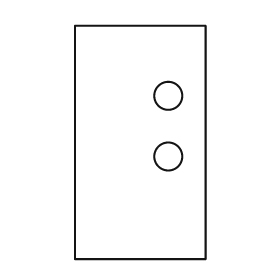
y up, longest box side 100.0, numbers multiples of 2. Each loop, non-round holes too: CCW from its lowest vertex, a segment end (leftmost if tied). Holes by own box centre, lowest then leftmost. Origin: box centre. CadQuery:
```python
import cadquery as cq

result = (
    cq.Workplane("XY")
    .moveTo(-28.0, -50.0)
    .lineTo(28.0, -50.0)
    .lineTo(28.0, 50.0)
    .lineTo(-28.0, 50.0)
    .close()
    .moveTo(12.0, -6.0)
    .circle(6.0)
    .moveTo(12.0, 20.0)
    .circle(6.0)
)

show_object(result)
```